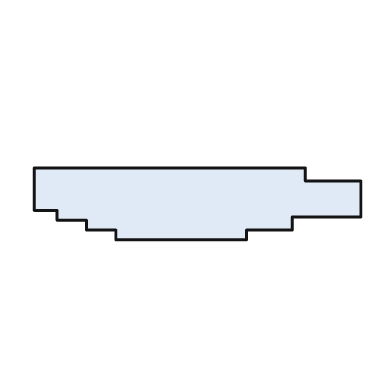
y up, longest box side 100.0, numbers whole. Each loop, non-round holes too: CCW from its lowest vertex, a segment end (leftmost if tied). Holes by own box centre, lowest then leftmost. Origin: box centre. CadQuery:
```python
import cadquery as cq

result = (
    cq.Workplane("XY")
    .moveTo(-25.0, -11.0)
    .lineTo(15.0, -11.0)
    .lineTo(15.0, -8.0)
    .lineTo(29.0, -8.0)
    .lineTo(29.0, -4.0)
    .lineTo(50.0, -4.0)
    .lineTo(50.0, 7.0)
    .lineTo(33.0, 7.0)
    .lineTo(33.0, 11.0)
    .lineTo(-50.0, 11.0)
    .lineTo(-50.0, -2.0)
    .lineTo(-43.0, -2.0)
    .lineTo(-43.0, -5.0)
    .lineTo(-34.0, -5.0)
    .lineTo(-34.0, -8.0)
    .lineTo(-25.0, -8.0)
    .close()
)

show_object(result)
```